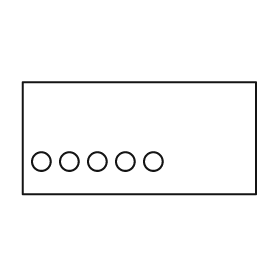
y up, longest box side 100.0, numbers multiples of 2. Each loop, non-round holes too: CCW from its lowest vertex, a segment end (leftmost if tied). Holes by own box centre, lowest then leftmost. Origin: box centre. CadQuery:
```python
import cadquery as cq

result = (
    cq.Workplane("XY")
    .moveTo(-50.0, -24.0)
    .lineTo(50.0, -24.0)
    .lineTo(50.0, 24.0)
    .lineTo(-50.0, 24.0)
    .close()
    .moveTo(-42.0, -10.0)
    .circle(4.0)
    .moveTo(-30.0, -10.0)
    .circle(4.0)
    .moveTo(-18.0, -10.0)
    .circle(4.0)
    .moveTo(-6.0, -10.0)
    .circle(4.0)
    .moveTo(6.0, -10.0)
    .circle(4.0)
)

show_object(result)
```